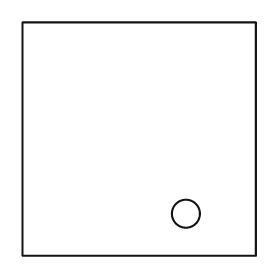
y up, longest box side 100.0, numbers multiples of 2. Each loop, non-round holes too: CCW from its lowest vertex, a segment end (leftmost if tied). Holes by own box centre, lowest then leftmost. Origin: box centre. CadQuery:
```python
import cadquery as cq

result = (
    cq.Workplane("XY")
    .moveTo(-50.0, -50.0)
    .lineTo(50.0, -50.0)
    .lineTo(50.0, 50.0)
    .lineTo(-50.0, 50.0)
    .close()
    .moveTo(20.0, -32.0)
    .circle(6.0)
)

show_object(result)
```